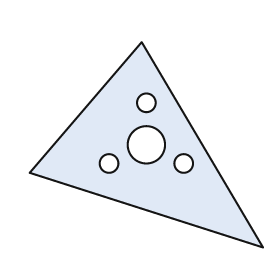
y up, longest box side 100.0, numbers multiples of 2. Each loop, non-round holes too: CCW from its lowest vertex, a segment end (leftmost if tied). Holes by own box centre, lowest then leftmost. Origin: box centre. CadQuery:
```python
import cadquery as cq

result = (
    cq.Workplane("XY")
    .moveTo(50.0, -44.0)
    .lineTo(-2.0, 44.0)
    .lineTo(-50.0, -12.0)
    .close()
    .moveTo(-16.0, -8.0)
    .circle(4.0)
    .moveTo(16.0, -8.0)
    .circle(4.0)
    .moveTo(0.0, 0.0)
    .circle(8.0)
    .moveTo(0.0, 18.0)
    .circle(4.0)
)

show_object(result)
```